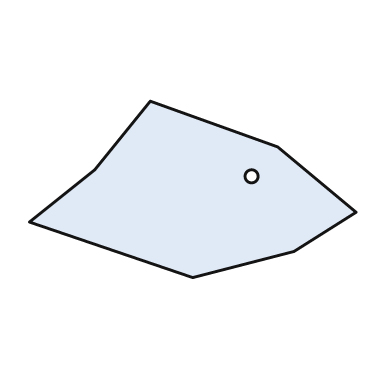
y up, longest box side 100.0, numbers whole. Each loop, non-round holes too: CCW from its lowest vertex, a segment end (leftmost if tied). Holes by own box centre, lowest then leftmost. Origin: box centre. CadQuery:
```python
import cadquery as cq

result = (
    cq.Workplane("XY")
    .moveTo(0.0, -27.0)
    .lineTo(31.0, -19.0)
    .lineTo(50.0, -7.0)
    .lineTo(26.0, 13.0)
    .lineTo(-13.0, 27.0)
    .lineTo(-30.0, 6.0)
    .lineTo(-50.0, -10.0)
    .close()
    .moveTo(18.0, 4.0)
    .circle(2.0)
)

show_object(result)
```